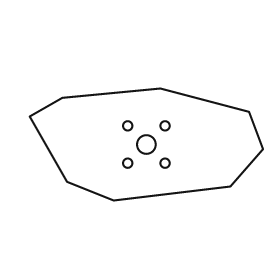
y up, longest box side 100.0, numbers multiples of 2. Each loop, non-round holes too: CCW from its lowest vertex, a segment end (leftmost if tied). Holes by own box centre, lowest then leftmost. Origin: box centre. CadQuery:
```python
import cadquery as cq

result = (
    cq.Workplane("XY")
    .moveTo(-14.0, -24.0)
    .lineTo(36.0, -18.0)
    .lineTo(50.0, -2.0)
    .lineTo(44.0, 14.0)
    .lineTo(6.0, 24.0)
    .lineTo(-36.0, 20.0)
    .lineTo(-50.0, 12.0)
    .lineTo(-34.0, -16.0)
    .close()
    .moveTo(-8.0, -8.0)
    .circle(2.0)
    .moveTo(8.0, -8.0)
    .circle(2.0)
    .moveTo(0.0, 0.0)
    .circle(4.0)
    .moveTo(-8.0, 8.0)
    .circle(2.0)
    .moveTo(8.0, 8.0)
    .circle(2.0)
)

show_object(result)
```